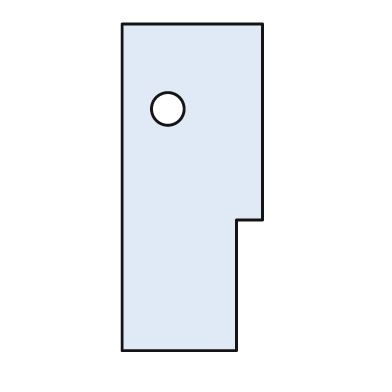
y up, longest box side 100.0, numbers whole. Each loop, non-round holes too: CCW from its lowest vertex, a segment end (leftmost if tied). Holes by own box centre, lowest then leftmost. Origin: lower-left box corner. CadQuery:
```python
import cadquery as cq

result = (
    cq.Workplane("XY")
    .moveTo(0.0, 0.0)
    .lineTo(35.0, 0.0)
    .lineTo(35.0, 40.0)
    .lineTo(43.0, 40.0)
    .lineTo(43.0, 100.0)
    .lineTo(0.0, 100.0)
    .close()
    .moveTo(14.0, 74.0)
    .circle(5.0)
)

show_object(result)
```